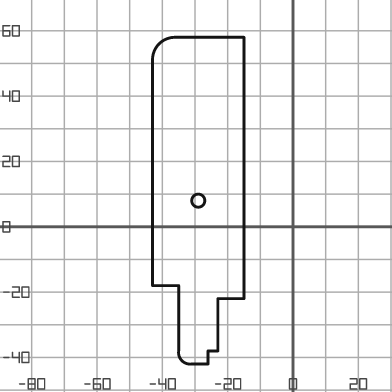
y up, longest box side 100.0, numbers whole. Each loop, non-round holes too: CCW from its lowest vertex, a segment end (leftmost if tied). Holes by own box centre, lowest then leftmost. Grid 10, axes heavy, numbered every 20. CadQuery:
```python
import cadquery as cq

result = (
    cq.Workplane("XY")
    .moveTo(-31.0, -42.0)
    .lineTo(-26.0, -42.0)
    .lineTo(-26.0, -38.0)
    .lineTo(-23.0, -38.0)
    .lineTo(-23.0, -22.0)
    .lineTo(-15.0, -22.0)
    .lineTo(-15.0, 58.0)
    .lineTo(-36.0, 58.0)
    .threePointArc((-41.0, 56.0), (-43.0, 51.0))
    .lineTo(-43.0, -18.0)
    .lineTo(-35.0, -18.0)
    .lineTo(-35.0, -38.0)
    .threePointArc((-34.0, -41.0), (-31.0, -42.0))
    .close()
    .moveTo(-29.0, 8.0)
    .circle(2.0)
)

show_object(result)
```